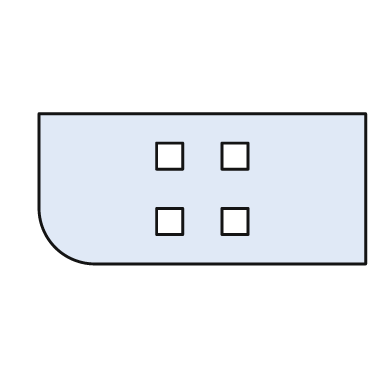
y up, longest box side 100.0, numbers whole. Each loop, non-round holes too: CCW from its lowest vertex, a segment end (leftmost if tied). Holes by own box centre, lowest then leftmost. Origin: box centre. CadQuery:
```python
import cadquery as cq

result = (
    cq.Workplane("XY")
    .moveTo(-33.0, -23.0)
    .lineTo(50.0, -23.0)
    .lineTo(50.0, 23.0)
    .lineTo(-50.0, 23.0)
    .lineTo(-50.0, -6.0)
    .threePointArc((-45.0, -18.0), (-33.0, -23.0))
    .close()
    .moveTo(-14.0, -14.0)
    .lineTo(-6.0, -14.0)
    .lineTo(-6.0, -6.0)
    .lineTo(-14.0, -6.0)
    .close()
    .moveTo(6.0, -14.0)
    .lineTo(14.0, -14.0)
    .lineTo(14.0, -6.0)
    .lineTo(6.0, -6.0)
    .close()
    .moveTo(-14.0, 6.0)
    .lineTo(-6.0, 6.0)
    .lineTo(-6.0, 14.0)
    .lineTo(-14.0, 14.0)
    .close()
    .moveTo(6.0, 6.0)
    .lineTo(14.0, 6.0)
    .lineTo(14.0, 14.0)
    .lineTo(6.0, 14.0)
    .close()
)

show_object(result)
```